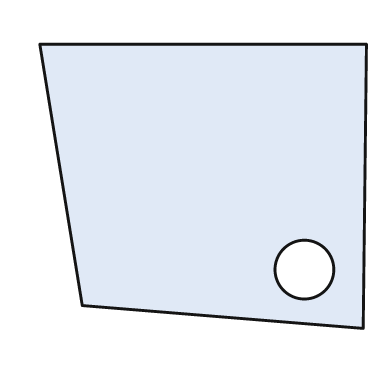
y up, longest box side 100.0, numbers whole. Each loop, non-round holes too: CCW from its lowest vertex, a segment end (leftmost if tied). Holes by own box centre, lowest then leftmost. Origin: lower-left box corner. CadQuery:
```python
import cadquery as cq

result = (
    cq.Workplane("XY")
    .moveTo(99.0, 0.0)
    .lineTo(100.0, 87.0)
    .lineTo(0.0, 87.0)
    .lineTo(13.0, 7.0)
    .close()
    .moveTo(81.0, 18.0)
    .circle(9.0)
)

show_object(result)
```